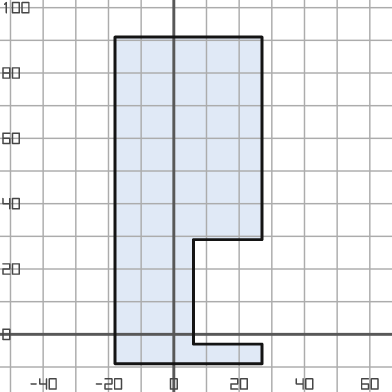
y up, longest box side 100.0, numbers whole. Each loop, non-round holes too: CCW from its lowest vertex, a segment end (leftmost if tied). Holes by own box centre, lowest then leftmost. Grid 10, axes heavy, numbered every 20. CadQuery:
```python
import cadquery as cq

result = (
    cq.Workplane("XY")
    .moveTo(-18.0, -9.0)
    .lineTo(27.0, -9.0)
    .lineTo(27.0, -3.0)
    .lineTo(6.0, -3.0)
    .lineTo(6.0, 29.0)
    .lineTo(27.0, 29.0)
    .lineTo(27.0, 91.0)
    .lineTo(-18.0, 91.0)
    .close()
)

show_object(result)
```